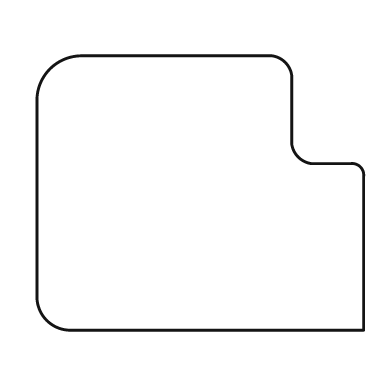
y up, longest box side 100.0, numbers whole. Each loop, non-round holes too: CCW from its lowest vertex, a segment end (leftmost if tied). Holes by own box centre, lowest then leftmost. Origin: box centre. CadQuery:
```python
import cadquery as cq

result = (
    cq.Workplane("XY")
    .moveTo(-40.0, -42.0)
    .lineTo(50.0, -42.0)
    .lineTo(50.0, 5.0)
    .threePointArc((49.0, 8.0), (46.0, 9.0))
    .lineTo(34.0, 9.0)
    .threePointArc((30.0, 11.0), (28.0, 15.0))
    .lineTo(28.0, 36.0)
    .threePointArc((26.0, 40.0), (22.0, 42.0))
    .lineTo(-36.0, 42.0)
    .threePointArc((-46.0, 38.0), (-50.0, 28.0))
    .lineTo(-50.0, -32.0)
    .threePointArc((-47.0, -39.0), (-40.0, -42.0))
    .close()
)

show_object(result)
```